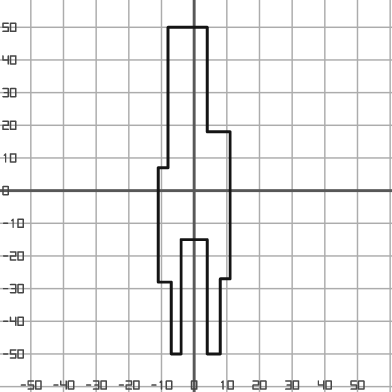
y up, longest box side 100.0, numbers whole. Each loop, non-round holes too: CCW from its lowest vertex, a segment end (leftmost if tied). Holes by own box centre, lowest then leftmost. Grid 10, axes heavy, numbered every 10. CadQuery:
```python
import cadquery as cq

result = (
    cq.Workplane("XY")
    .moveTo(-7.0, -50.0)
    .lineTo(-4.0, -50.0)
    .lineTo(-4.0, -15.0)
    .lineTo(4.0, -15.0)
    .lineTo(4.0, -50.0)
    .lineTo(8.0, -50.0)
    .lineTo(8.0, -27.0)
    .lineTo(11.0, -27.0)
    .lineTo(11.0, 18.0)
    .lineTo(4.0, 18.0)
    .lineTo(4.0, 50.0)
    .lineTo(-8.0, 50.0)
    .lineTo(-8.0, 7.0)
    .lineTo(-11.0, 7.0)
    .lineTo(-11.0, -28.0)
    .lineTo(-7.0, -28.0)
    .close()
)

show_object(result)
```